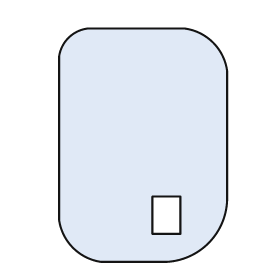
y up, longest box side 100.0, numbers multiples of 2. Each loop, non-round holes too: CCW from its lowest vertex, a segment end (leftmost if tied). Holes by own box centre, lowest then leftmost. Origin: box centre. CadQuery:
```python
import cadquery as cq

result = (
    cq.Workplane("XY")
    .moveTo(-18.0, -50.0)
    .lineTo(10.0, -50.0)
    .threePointArc((28.0, -42.0), (36.0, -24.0))
    .lineTo(36.0, 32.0)
    .threePointArc((30.0, 44.0), (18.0, 50.0))
    .lineTo(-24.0, 50.0)
    .threePointArc((-32.0, 46.0), (-36.0, 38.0))
    .lineTo(-36.0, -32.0)
    .threePointArc((-30.0, -44.0), (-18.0, -50.0))
    .close()
    .moveTo(4.0, -38.0)
    .lineTo(16.0, -38.0)
    .lineTo(16.0, -22.0)
    .lineTo(4.0, -22.0)
    .close()
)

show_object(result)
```